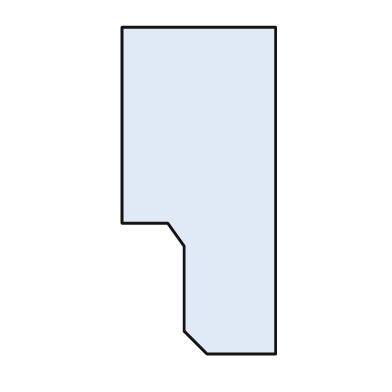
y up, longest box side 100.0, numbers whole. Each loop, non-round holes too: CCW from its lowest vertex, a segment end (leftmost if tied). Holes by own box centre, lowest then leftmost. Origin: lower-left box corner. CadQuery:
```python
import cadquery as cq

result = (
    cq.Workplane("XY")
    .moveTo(26.0, 0.0)
    .lineTo(47.0, 0.0)
    .lineTo(47.0, 100.0)
    .lineTo(0.0, 100.0)
    .lineTo(0.0, 40.0)
    .lineTo(14.0, 40.0)
    .lineTo(19.0, 33.0)
    .lineTo(19.0, 7.0)
    .close()
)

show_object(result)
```